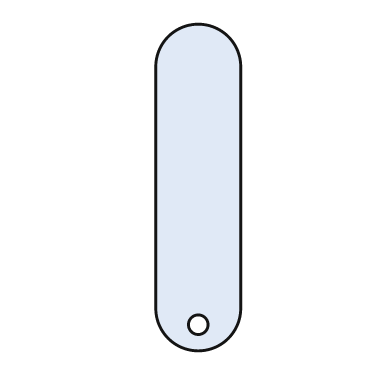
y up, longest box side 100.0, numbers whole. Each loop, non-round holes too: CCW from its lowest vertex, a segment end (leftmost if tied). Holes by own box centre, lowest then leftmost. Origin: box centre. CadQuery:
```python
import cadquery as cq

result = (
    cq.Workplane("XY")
    .moveTo(-13.0, -37.0)
    .threePointArc((0.0, -50.0), (13.0, -37.0))
    .lineTo(13.0, 37.0)
    .threePointArc((0.0, 50.0), (-13.0, 37.0))
    .close()
    .moveTo(0.0, -42.0)
    .circle(3.0)
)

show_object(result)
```